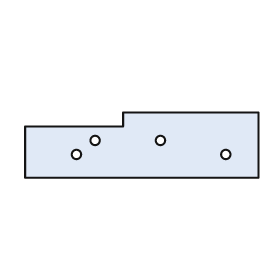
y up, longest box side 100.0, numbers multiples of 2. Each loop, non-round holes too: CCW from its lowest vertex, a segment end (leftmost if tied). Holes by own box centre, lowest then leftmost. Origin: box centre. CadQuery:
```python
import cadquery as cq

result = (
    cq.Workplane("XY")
    .moveTo(-50.0, -14.0)
    .lineTo(50.0, -14.0)
    .lineTo(50.0, 14.0)
    .lineTo(-8.0, 14.0)
    .lineTo(-8.0, 8.0)
    .lineTo(-50.0, 8.0)
    .close()
    .moveTo(-28.0, -4.0)
    .circle(2.0)
    .moveTo(36.0, -4.0)
    .circle(2.0)
    .moveTo(-20.0, 2.0)
    .circle(2.0)
    .moveTo(8.0, 2.0)
    .circle(2.0)
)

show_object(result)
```